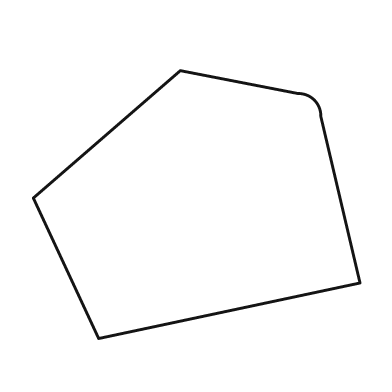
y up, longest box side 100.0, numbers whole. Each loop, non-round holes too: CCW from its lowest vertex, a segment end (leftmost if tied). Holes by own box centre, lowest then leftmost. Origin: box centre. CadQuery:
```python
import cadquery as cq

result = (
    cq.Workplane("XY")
    .moveTo(-30.0, -41.0)
    .lineTo(50.0, -24.0)
    .lineTo(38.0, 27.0)
    .threePointArc((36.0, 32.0), (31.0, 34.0))
    .lineTo(-5.0, 41.0)
    .lineTo(-50.0, 2.0)
    .close()
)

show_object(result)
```